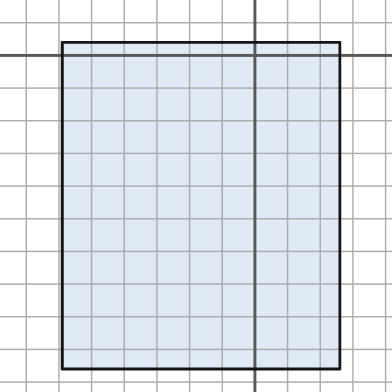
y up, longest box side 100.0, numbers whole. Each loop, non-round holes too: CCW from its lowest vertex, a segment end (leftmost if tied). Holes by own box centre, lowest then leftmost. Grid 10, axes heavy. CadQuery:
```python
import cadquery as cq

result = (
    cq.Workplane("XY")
    .moveTo(-59.0, -96.0)
    .lineTo(26.0, -96.0)
    .lineTo(26.0, 4.0)
    .lineTo(-59.0, 4.0)
    .close()
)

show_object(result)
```